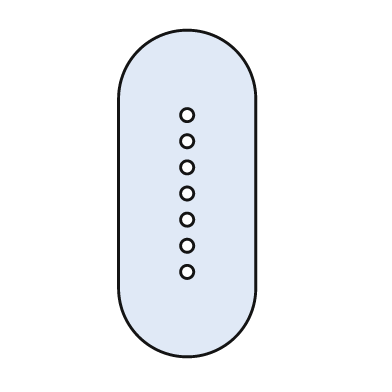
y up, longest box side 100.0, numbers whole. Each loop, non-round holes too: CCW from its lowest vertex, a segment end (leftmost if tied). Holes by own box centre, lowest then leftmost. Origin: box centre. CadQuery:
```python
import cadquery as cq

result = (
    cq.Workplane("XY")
    .moveTo(-21.0, -29.0)
    .threePointArc((0.0, -50.0), (21.0, -29.0))
    .lineTo(21.0, 29.0)
    .threePointArc((0.0, 50.0), (-21.0, 29.0))
    .close()
    .moveTo(0.0, -24.0)
    .circle(2.0)
    .moveTo(0.0, -16.0)
    .circle(2.0)
    .moveTo(0.0, -8.0)
    .circle(2.0)
    .moveTo(0.0, 0.0)
    .circle(2.0)
    .moveTo(0.0, 8.0)
    .circle(2.0)
    .moveTo(0.0, 16.0)
    .circle(2.0)
    .moveTo(0.0, 24.0)
    .circle(2.0)
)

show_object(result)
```